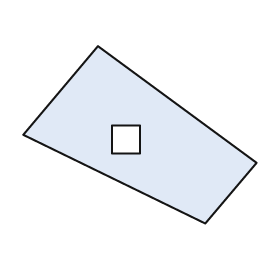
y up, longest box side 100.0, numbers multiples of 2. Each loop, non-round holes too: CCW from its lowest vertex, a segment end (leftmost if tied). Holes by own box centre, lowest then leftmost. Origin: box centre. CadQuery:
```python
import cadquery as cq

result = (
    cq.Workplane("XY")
    .moveTo(28.0, -38.0)
    .lineTo(50.0, -12.0)
    .lineTo(-18.0, 38.0)
    .lineTo(-50.0, 0.0)
    .close()
    .moveTo(-12.0, -8.0)
    .lineTo(0.0, -8.0)
    .lineTo(0.0, 4.0)
    .lineTo(-12.0, 4.0)
    .close()
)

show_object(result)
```